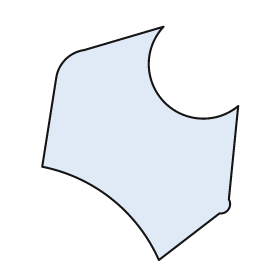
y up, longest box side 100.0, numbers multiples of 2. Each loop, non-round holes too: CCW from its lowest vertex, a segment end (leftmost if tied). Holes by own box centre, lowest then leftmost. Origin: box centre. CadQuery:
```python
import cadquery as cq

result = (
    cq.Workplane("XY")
    .moveTo(8.0, -50.0)
    .lineTo(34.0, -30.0)
    .threePointArc((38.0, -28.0), (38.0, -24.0))
    .lineTo(42.0, 16.0)
    .threePointArc((10.0, 18.0), (10.0, 50.0))
    .lineTo(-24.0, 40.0)
    .threePointArc((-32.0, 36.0), (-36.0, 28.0))
    .lineTo(-42.0, -10.0)
    .threePointArc((-12.0, -24.0), (8.0, -50.0))
    .close()
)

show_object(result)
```